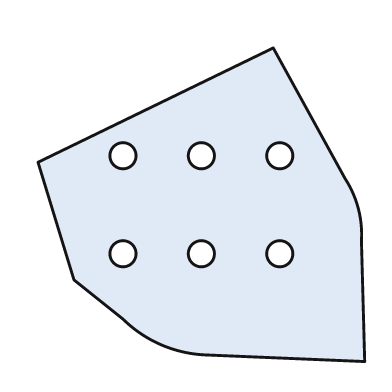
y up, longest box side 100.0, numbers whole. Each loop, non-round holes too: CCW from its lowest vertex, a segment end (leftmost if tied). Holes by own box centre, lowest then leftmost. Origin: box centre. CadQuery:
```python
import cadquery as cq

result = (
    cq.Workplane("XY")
    .moveTo(50.0, -48.0)
    .lineTo(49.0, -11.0)
    .threePointArc((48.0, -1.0), (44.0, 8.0))
    .lineTo(22.0, 48.0)
    .lineTo(-50.0, 13.0)
    .lineTo(-39.0, -23.0)
    .lineTo(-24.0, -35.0)
    .threePointArc((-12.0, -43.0), (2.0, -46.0))
    .close()
    .moveTo(-24.0, -15.0)
    .circle(4.0)
    .moveTo(0.0, -15.0)
    .circle(4.0)
    .moveTo(24.0, -15.0)
    .circle(4.0)
    .moveTo(-24.0, 15.0)
    .circle(4.0)
    .moveTo(0.0, 15.0)
    .circle(4.0)
    .moveTo(24.0, 15.0)
    .circle(4.0)
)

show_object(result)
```